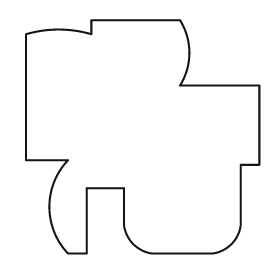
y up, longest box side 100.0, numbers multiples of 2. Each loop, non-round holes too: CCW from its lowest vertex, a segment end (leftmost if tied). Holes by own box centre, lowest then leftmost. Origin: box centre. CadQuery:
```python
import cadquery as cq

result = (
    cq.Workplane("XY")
    .moveTo(-32.0, -50.0)
    .lineTo(-24.0, -50.0)
    .lineTo(-24.0, -22.0)
    .lineTo(-8.0, -22.0)
    .lineTo(-8.0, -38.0)
    .threePointArc((-4.0, -46.0), (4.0, -50.0))
    .lineTo(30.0, -50.0)
    .threePointArc((38.0, -46.0), (42.0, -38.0))
    .lineTo(42.0, -12.0)
    .lineTo(50.0, -12.0)
    .lineTo(50.0, 22.0)
    .lineTo(16.0, 22.0)
    .threePointArc((20.0, 36.0), (16.0, 50.0))
    .lineTo(-22.0, 50.0)
    .lineTo(-22.0, 44.0)
    .threePointArc((-36.0, 46.0), (-50.0, 44.0))
    .lineTo(-50.0, -10.0)
    .lineTo(-32.0, -10.0)
    .threePointArc((-40.0, -30.0), (-32.0, -50.0))
    .close()
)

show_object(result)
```